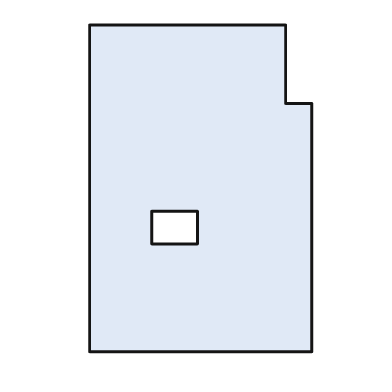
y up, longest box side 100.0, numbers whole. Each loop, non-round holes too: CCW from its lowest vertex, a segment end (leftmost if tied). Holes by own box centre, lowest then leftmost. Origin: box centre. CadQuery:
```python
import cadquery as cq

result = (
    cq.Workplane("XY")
    .moveTo(-34.0, -50.0)
    .lineTo(34.0, -50.0)
    .lineTo(34.0, 26.0)
    .lineTo(26.0, 26.0)
    .lineTo(26.0, 50.0)
    .lineTo(-34.0, 50.0)
    .close()
    .moveTo(-15.0, -17.0)
    .lineTo(-1.0, -17.0)
    .lineTo(-1.0, -7.0)
    .lineTo(-15.0, -7.0)
    .close()
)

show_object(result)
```